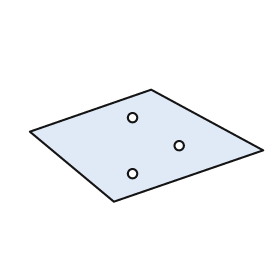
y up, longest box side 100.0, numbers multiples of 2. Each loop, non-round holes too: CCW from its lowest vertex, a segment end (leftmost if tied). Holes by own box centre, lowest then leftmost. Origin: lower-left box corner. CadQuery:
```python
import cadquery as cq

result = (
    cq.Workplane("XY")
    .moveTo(36.0, 0.0)
    .lineTo(100.0, 22.0)
    .lineTo(52.0, 48.0)
    .lineTo(0.0, 30.0)
    .close()
    .moveTo(44.0, 12.0)
    .circle(2.0)
    .moveTo(64.0, 24.0)
    .circle(2.0)
    .moveTo(44.0, 36.0)
    .circle(2.0)
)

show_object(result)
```